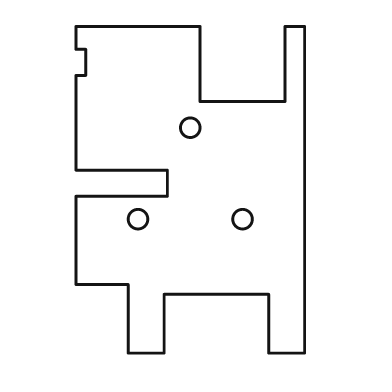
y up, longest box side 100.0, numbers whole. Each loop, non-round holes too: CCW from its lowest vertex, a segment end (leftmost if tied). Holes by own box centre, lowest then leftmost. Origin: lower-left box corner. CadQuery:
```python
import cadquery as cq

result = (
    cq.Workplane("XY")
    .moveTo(16.0, 0.0)
    .lineTo(27.0, 0.0)
    .lineTo(27.0, 18.0)
    .lineTo(59.0, 18.0)
    .lineTo(59.0, 0.0)
    .lineTo(70.0, 0.0)
    .lineTo(70.0, 100.0)
    .lineTo(64.0, 100.0)
    .lineTo(64.0, 77.0)
    .lineTo(38.0, 77.0)
    .lineTo(38.0, 100.0)
    .lineTo(0.0, 100.0)
    .lineTo(0.0, 93.0)
    .lineTo(3.0, 93.0)
    .lineTo(3.0, 85.0)
    .lineTo(0.0, 85.0)
    .lineTo(0.0, 56.0)
    .lineTo(28.0, 56.0)
    .lineTo(28.0, 48.0)
    .lineTo(0.0, 48.0)
    .lineTo(0.0, 21.0)
    .lineTo(16.0, 21.0)
    .close()
    .moveTo(19.0, 41.0)
    .circle(3.0)
    .moveTo(51.0, 41.0)
    .circle(3.0)
    .moveTo(35.0, 69.0)
    .circle(3.0)
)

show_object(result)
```